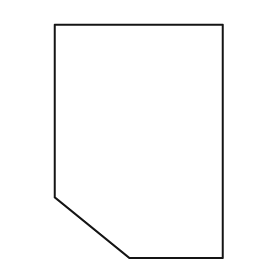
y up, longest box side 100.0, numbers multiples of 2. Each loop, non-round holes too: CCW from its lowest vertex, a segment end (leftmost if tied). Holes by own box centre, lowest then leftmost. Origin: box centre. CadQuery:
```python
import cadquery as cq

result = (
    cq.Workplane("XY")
    .moveTo(-4.0, -50.0)
    .lineTo(36.0, -50.0)
    .lineTo(36.0, 50.0)
    .lineTo(-36.0, 50.0)
    .lineTo(-36.0, -24.0)
    .close()
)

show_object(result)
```